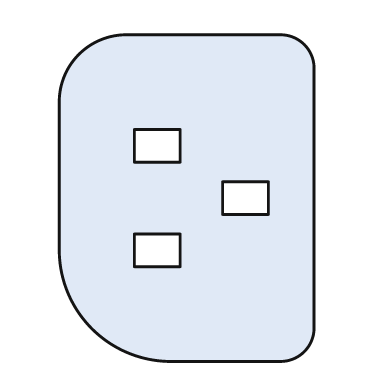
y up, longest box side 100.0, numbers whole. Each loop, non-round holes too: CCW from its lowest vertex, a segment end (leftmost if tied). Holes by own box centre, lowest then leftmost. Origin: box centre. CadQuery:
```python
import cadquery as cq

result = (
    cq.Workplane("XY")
    .moveTo(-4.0, -50.0)
    .lineTo(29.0, -50.0)
    .threePointArc((36.0, -47.0), (39.0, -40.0))
    .lineTo(39.0, 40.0)
    .threePointArc((36.0, 47.0), (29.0, 50.0))
    .lineTo(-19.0, 50.0)
    .threePointArc((-33.0, 44.0), (-39.0, 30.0))
    .lineTo(-39.0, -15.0)
    .threePointArc((-29.0, -40.0), (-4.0, -50.0))
    .close()
    .moveTo(-16.0, -21.0)
    .lineTo(-2.0, -21.0)
    .lineTo(-2.0, -11.0)
    .lineTo(-16.0, -11.0)
    .close()
    .moveTo(11.0, -5.0)
    .lineTo(25.0, -5.0)
    .lineTo(25.0, 5.0)
    .lineTo(11.0, 5.0)
    .close()
    .moveTo(-16.0, 11.0)
    .lineTo(-2.0, 11.0)
    .lineTo(-2.0, 21.0)
    .lineTo(-16.0, 21.0)
    .close()
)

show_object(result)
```